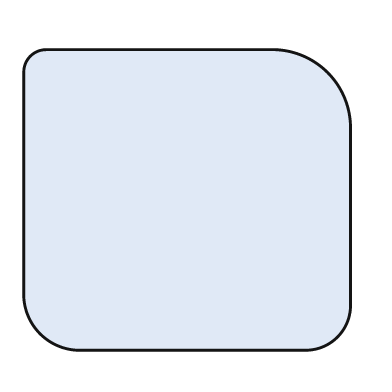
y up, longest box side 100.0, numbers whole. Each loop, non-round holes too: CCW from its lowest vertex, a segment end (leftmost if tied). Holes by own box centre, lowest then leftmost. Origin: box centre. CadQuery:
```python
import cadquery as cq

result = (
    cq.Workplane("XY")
    .moveTo(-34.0, -46.0)
    .lineTo(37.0, -46.0)
    .threePointArc((46.0, -42.0), (50.0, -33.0))
    .lineTo(50.0, 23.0)
    .threePointArc((43.0, 39.0), (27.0, 46.0))
    .lineTo(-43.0, 46.0)
    .threePointArc((-48.0, 44.0), (-50.0, 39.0))
    .lineTo(-50.0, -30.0)
    .threePointArc((-45.0, -41.0), (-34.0, -46.0))
    .close()
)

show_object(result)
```